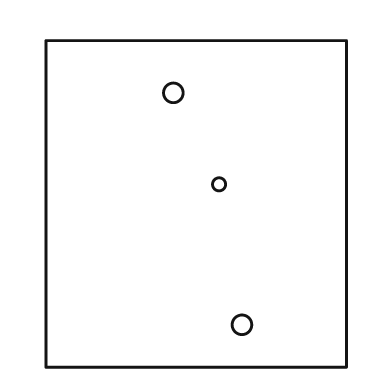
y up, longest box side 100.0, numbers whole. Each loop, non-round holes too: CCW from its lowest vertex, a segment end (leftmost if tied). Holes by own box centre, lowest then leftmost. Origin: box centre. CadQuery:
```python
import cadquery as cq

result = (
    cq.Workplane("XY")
    .moveTo(-46.0, -50.0)
    .lineTo(46.0, -50.0)
    .lineTo(46.0, 50.0)
    .lineTo(-46.0, 50.0)
    .close()
    .moveTo(14.0, -37.0)
    .circle(3.0)
    .moveTo(7.0, 6.0)
    .circle(2.0)
    .moveTo(-7.0, 34.0)
    .circle(3.0)
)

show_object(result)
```